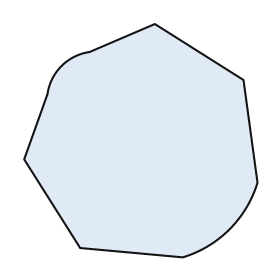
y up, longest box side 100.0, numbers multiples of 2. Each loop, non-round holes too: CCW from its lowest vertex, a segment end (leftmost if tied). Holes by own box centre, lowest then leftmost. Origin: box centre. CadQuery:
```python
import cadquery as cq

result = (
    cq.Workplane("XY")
    .moveTo(18.0, -50.0)
    .threePointArc((38.0, -38.0), (50.0, -18.0))
    .lineTo(44.0, 26.0)
    .lineTo(6.0, 50.0)
    .lineTo(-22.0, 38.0)
    .threePointArc((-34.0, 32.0), (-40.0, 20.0))
    .lineTo(-50.0, -8.0)
    .lineTo(-26.0, -46.0)
    .close()
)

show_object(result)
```